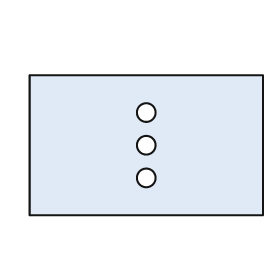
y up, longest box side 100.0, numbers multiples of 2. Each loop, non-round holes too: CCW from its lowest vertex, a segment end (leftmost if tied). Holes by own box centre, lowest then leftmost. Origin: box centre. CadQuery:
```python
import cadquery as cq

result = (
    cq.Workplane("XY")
    .moveTo(-50.0, -30.0)
    .lineTo(50.0, -30.0)
    .lineTo(50.0, 30.0)
    .lineTo(-50.0, 30.0)
    .close()
    .moveTo(0.0, -14.0)
    .circle(4.0)
    .moveTo(0.0, 0.0)
    .circle(4.0)
    .moveTo(0.0, 14.0)
    .circle(4.0)
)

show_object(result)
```